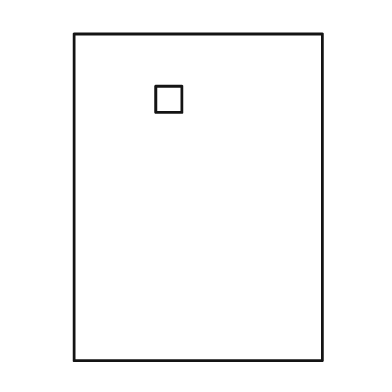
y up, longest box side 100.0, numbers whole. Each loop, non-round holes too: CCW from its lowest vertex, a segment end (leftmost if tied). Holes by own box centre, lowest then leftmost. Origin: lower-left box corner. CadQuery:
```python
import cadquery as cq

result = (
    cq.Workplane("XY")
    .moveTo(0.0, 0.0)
    .lineTo(76.0, 0.0)
    .lineTo(76.0, 100.0)
    .lineTo(0.0, 100.0)
    .close()
    .moveTo(25.0, 76.0)
    .lineTo(33.0, 76.0)
    .lineTo(33.0, 84.0)
    .lineTo(25.0, 84.0)
    .close()
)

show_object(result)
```